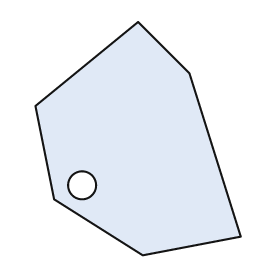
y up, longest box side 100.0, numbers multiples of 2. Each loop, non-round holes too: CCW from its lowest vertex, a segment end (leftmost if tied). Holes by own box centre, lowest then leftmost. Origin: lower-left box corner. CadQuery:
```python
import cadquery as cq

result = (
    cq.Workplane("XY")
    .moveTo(46.0, 0.0)
    .lineTo(88.0, 8.0)
    .lineTo(66.0, 78.0)
    .lineTo(44.0, 100.0)
    .lineTo(0.0, 64.0)
    .lineTo(8.0, 24.0)
    .close()
    .moveTo(20.0, 30.0)
    .circle(6.0)
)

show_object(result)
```